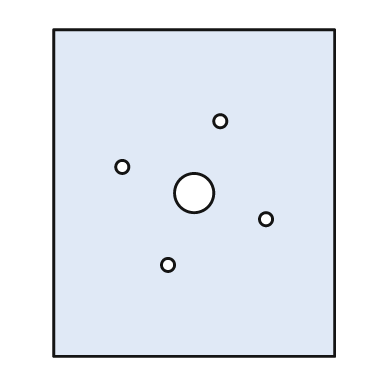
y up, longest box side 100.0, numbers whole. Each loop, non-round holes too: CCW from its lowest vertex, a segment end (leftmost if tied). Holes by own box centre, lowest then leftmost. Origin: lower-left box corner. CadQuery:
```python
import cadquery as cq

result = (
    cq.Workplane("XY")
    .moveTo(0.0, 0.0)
    .lineTo(86.0, 0.0)
    .lineTo(86.0, 100.0)
    .lineTo(0.0, 100.0)
    .close()
    .moveTo(35.0, 28.0)
    .circle(2.0)
    .moveTo(65.0, 42.0)
    .circle(2.0)
    .moveTo(43.0, 50.0)
    .circle(6.0)
    .moveTo(21.0, 58.0)
    .circle(2.0)
    .moveTo(51.0, 72.0)
    .circle(2.0)
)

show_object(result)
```